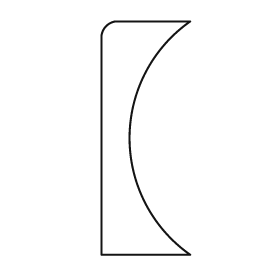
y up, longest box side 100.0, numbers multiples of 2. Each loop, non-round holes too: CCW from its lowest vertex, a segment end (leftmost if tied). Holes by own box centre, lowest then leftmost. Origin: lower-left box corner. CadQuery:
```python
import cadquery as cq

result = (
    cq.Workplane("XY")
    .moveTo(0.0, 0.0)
    .lineTo(38.0, 0.0)
    .threePointArc((12.0, 50.0), (38.0, 100.0))
    .lineTo(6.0, 100.0)
    .threePointArc((2.0, 98.0), (0.0, 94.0))
    .close()
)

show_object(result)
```